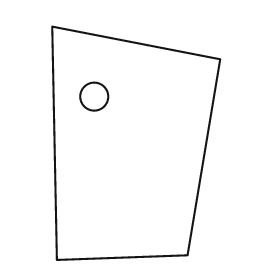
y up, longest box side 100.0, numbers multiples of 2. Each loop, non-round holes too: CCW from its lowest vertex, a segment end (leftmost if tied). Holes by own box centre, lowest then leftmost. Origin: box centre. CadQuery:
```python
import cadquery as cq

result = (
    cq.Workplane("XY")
    .moveTo(-34.0, -50.0)
    .lineTo(22.0, -48.0)
    .lineTo(36.0, 36.0)
    .lineTo(-36.0, 50.0)
    .close()
    .moveTo(-18.0, 20.0)
    .circle(6.0)
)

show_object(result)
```